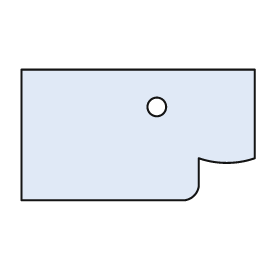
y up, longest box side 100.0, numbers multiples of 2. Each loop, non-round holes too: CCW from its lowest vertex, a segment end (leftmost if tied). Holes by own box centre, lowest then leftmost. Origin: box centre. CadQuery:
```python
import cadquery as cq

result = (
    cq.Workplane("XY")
    .moveTo(-50.0, -28.0)
    .lineTo(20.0, -28.0)
    .threePointArc((24.0, -26.0), (26.0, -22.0))
    .lineTo(26.0, -10.0)
    .threePointArc((38.0, -12.0), (50.0, -10.0))
    .lineTo(50.0, 28.0)
    .lineTo(-50.0, 28.0)
    .close()
    .moveTo(8.0, 12.0)
    .circle(4.0)
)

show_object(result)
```